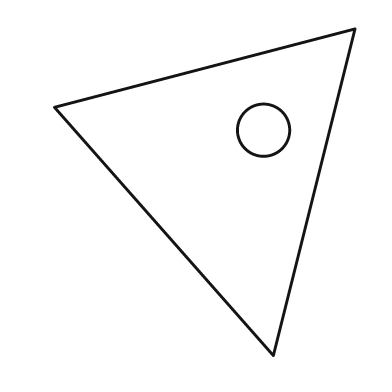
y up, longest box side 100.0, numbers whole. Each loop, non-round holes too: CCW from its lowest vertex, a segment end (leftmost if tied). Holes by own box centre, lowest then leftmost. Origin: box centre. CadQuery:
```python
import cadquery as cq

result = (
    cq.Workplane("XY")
    .moveTo(21.0, -50.0)
    .lineTo(46.0, 50.0)
    .lineTo(-46.0, 26.0)
    .close()
    .moveTo(18.0, 19.0)
    .circle(8.0)
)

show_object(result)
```